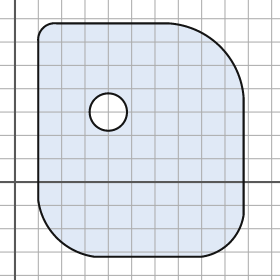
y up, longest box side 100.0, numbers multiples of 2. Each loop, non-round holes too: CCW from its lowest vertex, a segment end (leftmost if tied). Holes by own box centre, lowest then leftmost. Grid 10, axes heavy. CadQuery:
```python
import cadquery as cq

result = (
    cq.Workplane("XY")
    .moveTo(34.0, -32.0)
    .lineTo(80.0, -32.0)
    .threePointArc((92.0, -26.0), (98.0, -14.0))
    .lineTo(98.0, 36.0)
    .threePointArc((88.0, 58.0), (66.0, 68.0))
    .lineTo(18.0, 68.0)
    .threePointArc((12.0, 66.0), (10.0, 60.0))
    .lineTo(10.0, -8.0)
    .threePointArc((18.0, -24.0), (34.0, -32.0))
    .close()
    .moveTo(40.0, 30.0)
    .circle(8.0)
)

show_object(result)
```